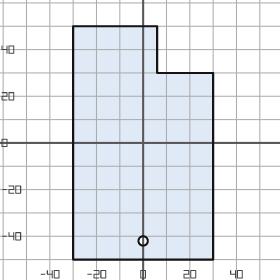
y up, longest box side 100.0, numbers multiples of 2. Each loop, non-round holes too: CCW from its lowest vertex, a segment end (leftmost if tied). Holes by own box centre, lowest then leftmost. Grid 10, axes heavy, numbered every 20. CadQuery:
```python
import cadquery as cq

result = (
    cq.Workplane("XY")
    .moveTo(-30.0, -50.0)
    .lineTo(30.0, -50.0)
    .lineTo(30.0, 30.0)
    .lineTo(6.0, 30.0)
    .lineTo(6.0, 50.0)
    .lineTo(-30.0, 50.0)
    .close()
    .moveTo(0.0, -42.0)
    .circle(2.0)
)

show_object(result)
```